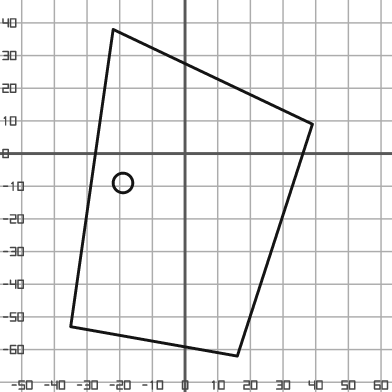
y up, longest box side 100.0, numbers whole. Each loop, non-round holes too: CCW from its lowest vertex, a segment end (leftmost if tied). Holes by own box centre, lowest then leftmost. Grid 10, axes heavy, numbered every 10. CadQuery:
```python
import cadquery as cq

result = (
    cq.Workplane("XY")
    .moveTo(16.0, -62.0)
    .lineTo(39.0, 9.0)
    .lineTo(-22.0, 38.0)
    .lineTo(-35.0, -53.0)
    .close()
    .moveTo(-19.0, -9.0)
    .circle(3.0)
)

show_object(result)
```